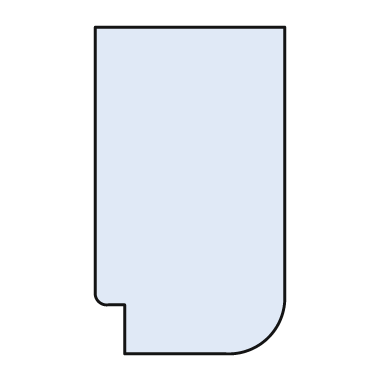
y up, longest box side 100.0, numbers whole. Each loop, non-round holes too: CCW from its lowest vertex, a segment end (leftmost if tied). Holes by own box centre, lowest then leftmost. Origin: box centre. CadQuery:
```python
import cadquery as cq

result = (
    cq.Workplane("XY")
    .moveTo(-20.0, -50.0)
    .lineTo(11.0, -50.0)
    .threePointArc((24.0, -45.0), (29.0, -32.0))
    .lineTo(29.0, 50.0)
    .lineTo(-29.0, 50.0)
    .lineTo(-29.0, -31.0)
    .threePointArc((-28.0, -34.0), (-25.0, -35.0))
    .lineTo(-20.0, -35.0)
    .close()
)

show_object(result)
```